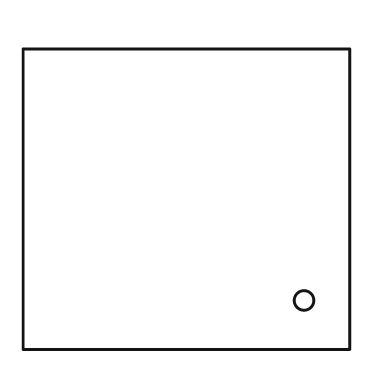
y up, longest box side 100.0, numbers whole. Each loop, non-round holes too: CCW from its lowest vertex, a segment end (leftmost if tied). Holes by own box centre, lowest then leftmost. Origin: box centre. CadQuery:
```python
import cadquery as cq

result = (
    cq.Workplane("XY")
    .moveTo(-50.0, -46.0)
    .lineTo(50.0, -46.0)
    .lineTo(50.0, 46.0)
    .lineTo(-50.0, 46.0)
    .close()
    .moveTo(36.0, -31.0)
    .circle(3.0)
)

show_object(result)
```